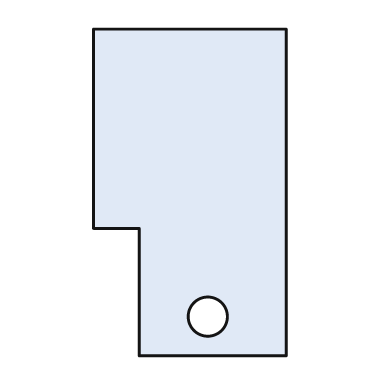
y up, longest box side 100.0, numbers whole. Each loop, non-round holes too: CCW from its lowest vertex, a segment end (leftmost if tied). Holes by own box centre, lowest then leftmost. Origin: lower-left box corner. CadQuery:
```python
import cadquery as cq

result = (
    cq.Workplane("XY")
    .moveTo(14.0, 0.0)
    .lineTo(59.0, 0.0)
    .lineTo(59.0, 100.0)
    .lineTo(0.0, 100.0)
    .lineTo(0.0, 39.0)
    .lineTo(14.0, 39.0)
    .close()
    .moveTo(35.0, 12.0)
    .circle(6.0)
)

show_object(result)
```